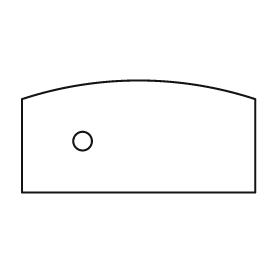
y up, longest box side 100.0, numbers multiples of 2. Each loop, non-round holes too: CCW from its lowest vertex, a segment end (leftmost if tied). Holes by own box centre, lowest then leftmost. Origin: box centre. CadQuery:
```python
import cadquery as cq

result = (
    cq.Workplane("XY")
    .moveTo(-50.0, -24.0)
    .lineTo(50.0, -24.0)
    .lineTo(50.0, 16.0)
    .threePointArc((0.0, 24.0), (-50.0, 16.0))
    .close()
    .moveTo(-24.0, -2.0)
    .circle(4.0)
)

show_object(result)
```